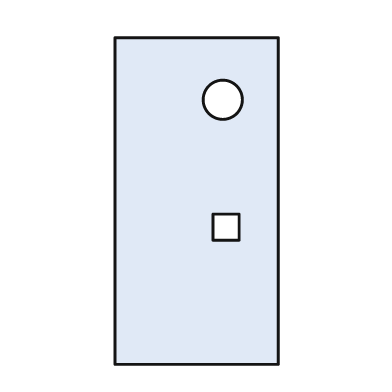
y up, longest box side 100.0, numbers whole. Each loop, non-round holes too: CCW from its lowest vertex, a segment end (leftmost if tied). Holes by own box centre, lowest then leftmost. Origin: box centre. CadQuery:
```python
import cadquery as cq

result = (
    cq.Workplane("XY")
    .moveTo(-25.0, -50.0)
    .lineTo(25.0, -50.0)
    .lineTo(25.0, 50.0)
    .lineTo(-25.0, 50.0)
    .close()
    .moveTo(5.0, -12.0)
    .lineTo(13.0, -12.0)
    .lineTo(13.0, -4.0)
    .lineTo(5.0, -4.0)
    .close()
    .moveTo(8.0, 31.0)
    .circle(6.0)
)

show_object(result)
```